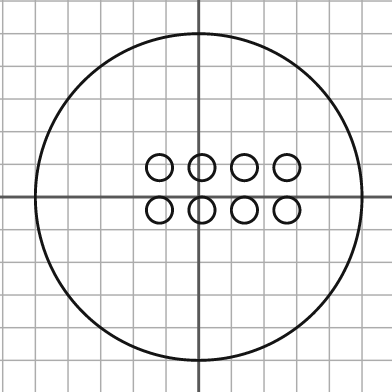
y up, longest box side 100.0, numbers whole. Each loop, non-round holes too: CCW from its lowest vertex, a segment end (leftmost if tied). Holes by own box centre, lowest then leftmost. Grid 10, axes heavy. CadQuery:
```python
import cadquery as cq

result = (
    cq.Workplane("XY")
    .moveTo(0.0, 0.0)
    .circle(50.0)
    .moveTo(-12.0, -4.0)
    .circle(4.0)
    .moveTo(1.0, -4.0)
    .circle(4.0)
    .moveTo(14.0, -4.0)
    .circle(4.0)
    .moveTo(27.0, -4.0)
    .circle(4.0)
    .moveTo(-12.0, 9.0)
    .circle(4.0)
    .moveTo(1.0, 9.0)
    .circle(4.0)
    .moveTo(14.0, 9.0)
    .circle(4.0)
    .moveTo(27.0, 9.0)
    .circle(4.0)
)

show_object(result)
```